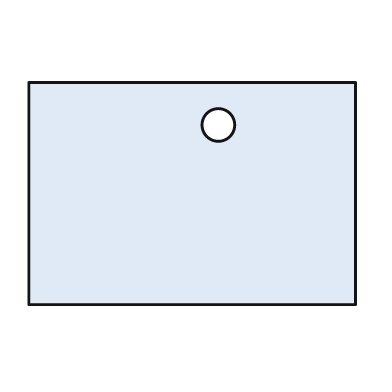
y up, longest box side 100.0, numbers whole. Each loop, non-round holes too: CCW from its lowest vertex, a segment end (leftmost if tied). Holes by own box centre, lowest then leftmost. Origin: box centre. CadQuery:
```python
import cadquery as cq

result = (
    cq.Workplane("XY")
    .moveTo(-50.0, -34.0)
    .lineTo(50.0, -34.0)
    .lineTo(50.0, 34.0)
    .lineTo(-50.0, 34.0)
    .close()
    .moveTo(8.0, 21.0)
    .circle(5.0)
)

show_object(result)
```